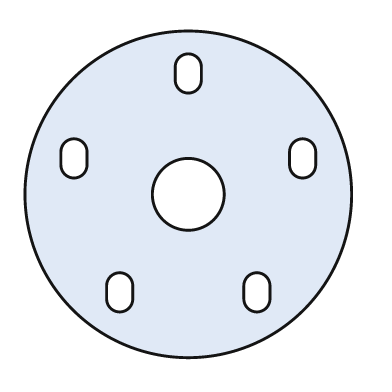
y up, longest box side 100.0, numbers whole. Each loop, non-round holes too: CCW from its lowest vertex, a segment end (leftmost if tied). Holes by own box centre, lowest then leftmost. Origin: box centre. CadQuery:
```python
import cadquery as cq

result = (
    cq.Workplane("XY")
    .moveTo(0.0, 0.0)
    .circle(50.0)
    .moveTo(-25.0, -32.0)
    .threePointArc((-21.0, -36.0), (-17.0, -32.0))
    .lineTo(-17.0, -28.0)
    .threePointArc((-21.0, -24.0), (-25.0, -28.0))
    .close()
    .moveTo(17.0, -32.0)
    .threePointArc((21.0, -36.0), (25.0, -32.0))
    .lineTo(25.0, -28.0)
    .threePointArc((21.0, -24.0), (17.0, -28.0))
    .close()
    .moveTo(0.0, 0.0)
    .circle(11.0)
    .moveTo(-39.0, 9.0)
    .threePointArc((-35.0, 5.0), (-31.0, 9.0))
    .lineTo(-31.0, 13.0)
    .threePointArc((-35.0, 17.0), (-39.0, 13.0))
    .close()
    .moveTo(31.0, 9.0)
    .threePointArc((35.0, 5.0), (39.0, 9.0))
    .lineTo(39.0, 13.0)
    .threePointArc((35.0, 17.0), (31.0, 13.0))
    .close()
    .moveTo(-4.0, 35.0)
    .threePointArc((0.0, 31.0), (4.0, 35.0))
    .lineTo(4.0, 39.0)
    .threePointArc((0.0, 43.0), (-4.0, 39.0))
    .close()
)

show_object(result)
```